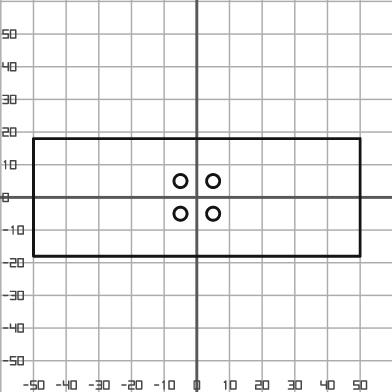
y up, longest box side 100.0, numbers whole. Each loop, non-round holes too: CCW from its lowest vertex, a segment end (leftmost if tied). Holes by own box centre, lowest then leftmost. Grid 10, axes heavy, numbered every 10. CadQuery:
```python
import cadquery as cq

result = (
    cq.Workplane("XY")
    .moveTo(-50.0, -18.0)
    .lineTo(50.0, -18.0)
    .lineTo(50.0, 18.0)
    .lineTo(-50.0, 18.0)
    .close()
    .moveTo(-5.0, -5.0)
    .circle(2.0)
    .moveTo(5.0, -5.0)
    .circle(2.0)
    .moveTo(-5.0, 5.0)
    .circle(2.0)
    .moveTo(5.0, 5.0)
    .circle(2.0)
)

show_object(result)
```